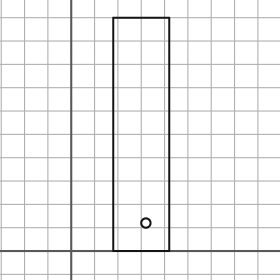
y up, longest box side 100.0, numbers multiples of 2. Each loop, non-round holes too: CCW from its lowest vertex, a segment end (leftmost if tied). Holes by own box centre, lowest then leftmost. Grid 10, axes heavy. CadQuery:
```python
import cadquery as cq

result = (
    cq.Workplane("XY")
    .moveTo(18.0, 0.0)
    .lineTo(42.0, 0.0)
    .lineTo(42.0, 100.0)
    .lineTo(18.0, 100.0)
    .close()
    .moveTo(32.0, 12.0)
    .circle(2.0)
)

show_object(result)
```